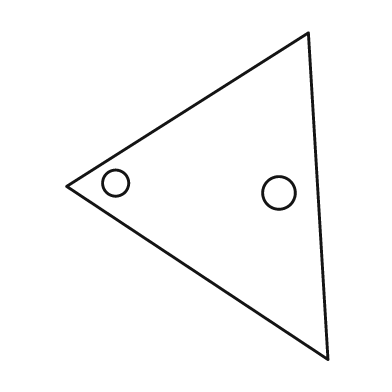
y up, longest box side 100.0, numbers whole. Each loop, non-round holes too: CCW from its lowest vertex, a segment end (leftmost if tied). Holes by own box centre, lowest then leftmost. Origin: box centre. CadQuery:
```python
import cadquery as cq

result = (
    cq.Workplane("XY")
    .moveTo(40.0, -50.0)
    .lineTo(34.0, 50.0)
    .lineTo(-40.0, 3.0)
    .close()
    .moveTo(25.0, 1.0)
    .circle(5.0)
    .moveTo(-25.0, 4.0)
    .circle(4.0)
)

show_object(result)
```